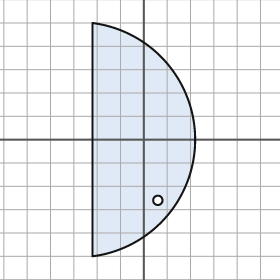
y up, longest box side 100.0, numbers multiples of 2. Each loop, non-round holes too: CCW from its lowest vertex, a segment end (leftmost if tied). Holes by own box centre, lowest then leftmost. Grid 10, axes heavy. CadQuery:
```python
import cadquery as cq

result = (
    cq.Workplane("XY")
    .moveTo(-22.0, -50.0)
    .threePointArc((22.0, 0.0), (-22.0, 50.0))
    .close()
    .moveTo(6.0, -26.0)
    .circle(2.0)
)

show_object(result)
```